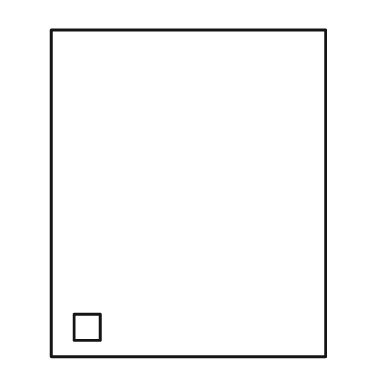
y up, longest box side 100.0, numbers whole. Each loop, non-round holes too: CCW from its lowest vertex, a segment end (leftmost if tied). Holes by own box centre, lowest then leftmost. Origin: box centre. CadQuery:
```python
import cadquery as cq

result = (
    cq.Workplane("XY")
    .moveTo(-42.0, -50.0)
    .lineTo(42.0, -50.0)
    .lineTo(42.0, 50.0)
    .lineTo(-42.0, 50.0)
    .close()
    .moveTo(-35.0, -45.0)
    .lineTo(-27.0, -45.0)
    .lineTo(-27.0, -37.0)
    .lineTo(-35.0, -37.0)
    .close()
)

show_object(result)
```